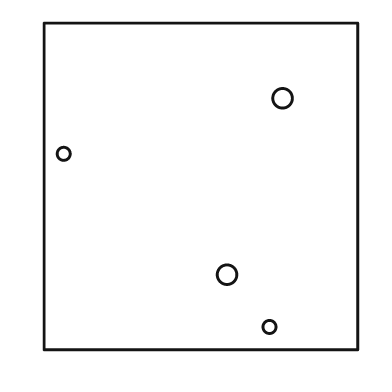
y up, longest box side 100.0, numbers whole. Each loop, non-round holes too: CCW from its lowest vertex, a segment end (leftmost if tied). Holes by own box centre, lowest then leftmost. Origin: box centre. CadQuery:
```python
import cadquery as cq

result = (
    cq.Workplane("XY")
    .moveTo(-48.0, -50.0)
    .lineTo(48.0, -50.0)
    .lineTo(48.0, 50.0)
    .lineTo(-48.0, 50.0)
    .close()
    .moveTo(21.0, -43.0)
    .circle(2.0)
    .moveTo(8.0, -27.0)
    .circle(3.0)
    .moveTo(-42.0, 10.0)
    .circle(2.0)
    .moveTo(25.0, 27.0)
    .circle(3.0)
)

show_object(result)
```